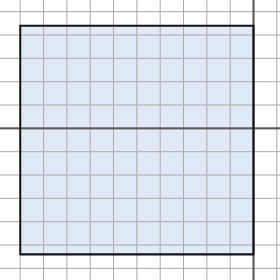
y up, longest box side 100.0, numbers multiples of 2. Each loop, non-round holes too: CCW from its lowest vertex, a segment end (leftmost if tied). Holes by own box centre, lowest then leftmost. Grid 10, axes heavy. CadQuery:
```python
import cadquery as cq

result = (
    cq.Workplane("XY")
    .moveTo(-100.0, -54.0)
    .lineTo(0.0, -54.0)
    .lineTo(0.0, 44.0)
    .lineTo(-100.0, 44.0)
    .close()
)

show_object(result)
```